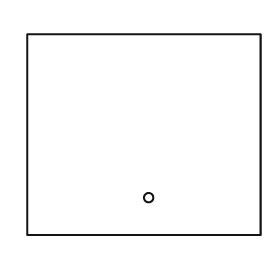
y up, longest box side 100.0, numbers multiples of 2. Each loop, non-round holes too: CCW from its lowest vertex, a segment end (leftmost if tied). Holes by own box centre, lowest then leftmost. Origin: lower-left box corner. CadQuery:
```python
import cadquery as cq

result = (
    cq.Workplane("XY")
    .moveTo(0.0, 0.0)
    .lineTo(100.0, 0.0)
    .lineTo(100.0, 86.0)
    .lineTo(0.0, 86.0)
    .close()
    .moveTo(52.0, 16.0)
    .circle(2.0)
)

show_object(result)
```